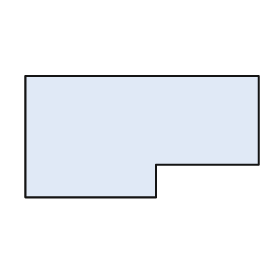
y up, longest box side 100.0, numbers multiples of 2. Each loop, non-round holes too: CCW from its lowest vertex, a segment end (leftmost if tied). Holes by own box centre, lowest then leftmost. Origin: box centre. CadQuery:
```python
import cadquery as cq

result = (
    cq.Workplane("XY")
    .moveTo(-50.0, -26.0)
    .lineTo(6.0, -26.0)
    .lineTo(6.0, -12.0)
    .lineTo(50.0, -12.0)
    .lineTo(50.0, 26.0)
    .lineTo(-50.0, 26.0)
    .close()
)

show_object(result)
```